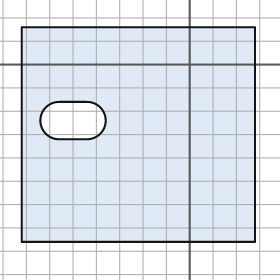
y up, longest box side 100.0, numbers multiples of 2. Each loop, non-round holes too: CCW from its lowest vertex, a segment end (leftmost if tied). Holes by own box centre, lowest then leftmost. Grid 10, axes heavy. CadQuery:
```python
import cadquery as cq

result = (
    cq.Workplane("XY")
    .moveTo(-72.0, -76.0)
    .lineTo(28.0, -76.0)
    .lineTo(28.0, 16.0)
    .lineTo(-72.0, 16.0)
    .close()
    .moveTo(-56.0, -32.0)
    .lineTo(-44.0, -32.0)
    .threePointArc((-36.0, -24.0), (-44.0, -16.0))
    .lineTo(-56.0, -16.0)
    .threePointArc((-64.0, -24.0), (-56.0, -32.0))
    .close()
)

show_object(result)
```